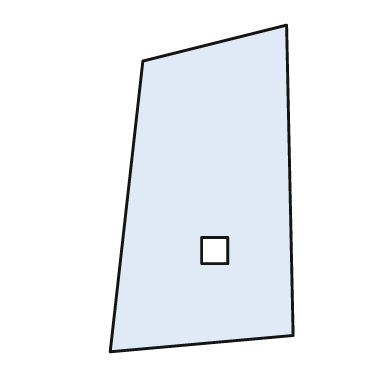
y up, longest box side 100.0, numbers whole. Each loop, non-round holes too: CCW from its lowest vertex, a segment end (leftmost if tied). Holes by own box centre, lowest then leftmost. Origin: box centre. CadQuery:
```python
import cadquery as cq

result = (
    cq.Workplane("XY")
    .moveTo(-28.0, -50.0)
    .lineTo(28.0, -45.0)
    .lineTo(26.0, 50.0)
    .lineTo(-18.0, 39.0)
    .close()
    .moveTo(0.0, -23.0)
    .lineTo(8.0, -23.0)
    .lineTo(8.0, -15.0)
    .lineTo(0.0, -15.0)
    .close()
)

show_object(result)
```